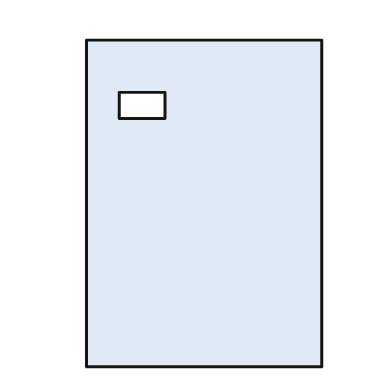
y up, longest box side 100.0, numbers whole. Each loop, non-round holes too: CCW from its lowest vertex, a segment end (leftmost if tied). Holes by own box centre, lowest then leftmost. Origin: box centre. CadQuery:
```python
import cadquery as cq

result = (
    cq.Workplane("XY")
    .moveTo(-36.0, -50.0)
    .lineTo(36.0, -50.0)
    .lineTo(36.0, 50.0)
    .lineTo(-36.0, 50.0)
    .close()
    .moveTo(-26.0, 26.0)
    .lineTo(-12.0, 26.0)
    .lineTo(-12.0, 34.0)
    .lineTo(-26.0, 34.0)
    .close()
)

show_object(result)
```